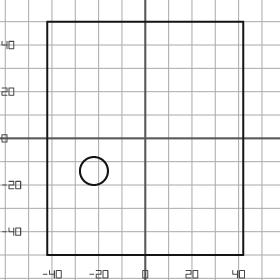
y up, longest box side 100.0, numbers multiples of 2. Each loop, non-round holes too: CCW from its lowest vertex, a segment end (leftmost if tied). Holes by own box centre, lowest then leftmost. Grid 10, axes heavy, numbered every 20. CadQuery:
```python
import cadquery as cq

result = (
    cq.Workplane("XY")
    .moveTo(-42.0, -50.0)
    .lineTo(42.0, -50.0)
    .lineTo(42.0, 50.0)
    .lineTo(-42.0, 50.0)
    .close()
    .moveTo(-22.0, -14.0)
    .circle(6.0)
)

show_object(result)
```